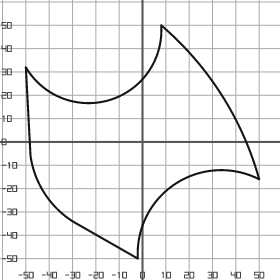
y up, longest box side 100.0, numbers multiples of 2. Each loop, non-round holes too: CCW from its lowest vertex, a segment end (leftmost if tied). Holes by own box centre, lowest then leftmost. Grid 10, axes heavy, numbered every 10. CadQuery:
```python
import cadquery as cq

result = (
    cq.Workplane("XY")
    .moveTo(-2.0, -50.0)
    .threePointArc((14.0, -18.0), (50.0, -16.0))
    .threePointArc((34.0, 20.0), (8.0, 50.0))
    .threePointArc((-14.0, 18.0), (-50.0, 32.0))
    .lineTo(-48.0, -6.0)
    .threePointArc((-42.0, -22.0), (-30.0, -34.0))
    .close()
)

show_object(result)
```